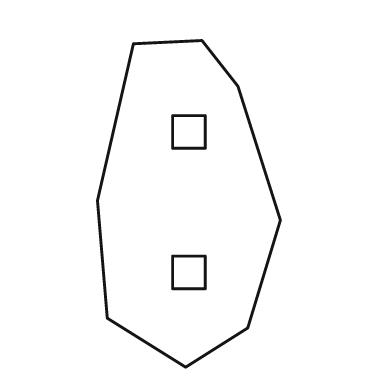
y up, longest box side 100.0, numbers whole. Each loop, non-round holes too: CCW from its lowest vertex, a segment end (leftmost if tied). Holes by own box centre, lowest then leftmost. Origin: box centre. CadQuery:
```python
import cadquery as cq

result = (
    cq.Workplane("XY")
    .moveTo(-1.0, -50.0)
    .lineTo(18.0, -38.0)
    .lineTo(28.0, -5.0)
    .lineTo(15.0, 36.0)
    .lineTo(4.0, 50.0)
    .lineTo(-17.0, 49.0)
    .lineTo(-28.0, 1.0)
    .lineTo(-25.0, -35.0)
    .close()
    .moveTo(-5.0, -26.0)
    .lineTo(5.0, -26.0)
    .lineTo(5.0, -16.0)
    .lineTo(-5.0, -16.0)
    .close()
    .moveTo(-5.0, 17.0)
    .lineTo(5.0, 17.0)
    .lineTo(5.0, 27.0)
    .lineTo(-5.0, 27.0)
    .close()
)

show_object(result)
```